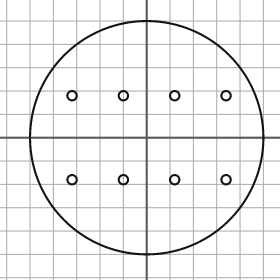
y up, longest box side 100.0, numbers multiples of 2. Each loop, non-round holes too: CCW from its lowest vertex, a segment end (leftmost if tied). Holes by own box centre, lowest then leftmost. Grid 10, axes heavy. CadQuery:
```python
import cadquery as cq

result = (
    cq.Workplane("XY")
    .moveTo(0.0, 0.0)
    .circle(50.0)
    .moveTo(-32.0, -18.0)
    .circle(2.0)
    .moveTo(-10.0, -18.0)
    .circle(2.0)
    .moveTo(12.0, -18.0)
    .circle(2.0)
    .moveTo(34.0, -18.0)
    .circle(2.0)
    .moveTo(-32.0, 18.0)
    .circle(2.0)
    .moveTo(-10.0, 18.0)
    .circle(2.0)
    .moveTo(12.0, 18.0)
    .circle(2.0)
    .moveTo(34.0, 18.0)
    .circle(2.0)
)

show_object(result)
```